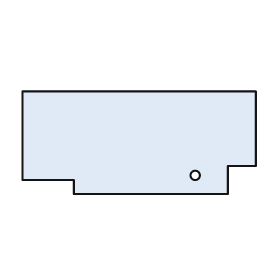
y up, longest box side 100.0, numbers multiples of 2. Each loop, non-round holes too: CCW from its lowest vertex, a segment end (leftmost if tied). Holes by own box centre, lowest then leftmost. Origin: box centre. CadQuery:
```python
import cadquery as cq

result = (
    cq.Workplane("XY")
    .moveTo(-28.0, -22.0)
    .lineTo(38.0, -22.0)
    .lineTo(38.0, -10.0)
    .lineTo(50.0, -10.0)
    .lineTo(50.0, 22.0)
    .lineTo(-50.0, 22.0)
    .lineTo(-50.0, -16.0)
    .lineTo(-28.0, -16.0)
    .close()
    .moveTo(24.0, -14.0)
    .circle(2.0)
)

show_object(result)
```